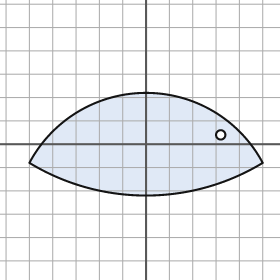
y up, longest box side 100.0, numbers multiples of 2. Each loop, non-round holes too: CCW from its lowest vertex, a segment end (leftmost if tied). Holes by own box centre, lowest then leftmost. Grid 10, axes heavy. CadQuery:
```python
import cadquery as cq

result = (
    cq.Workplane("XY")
    .moveTo(-50.0, -8.0)
    .threePointArc((0.0, -22.0), (50.0, -8.0))
    .threePointArc((0.0, 22.0), (-50.0, -8.0))
    .close()
    .moveTo(32.0, 4.0)
    .circle(2.0)
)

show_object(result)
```